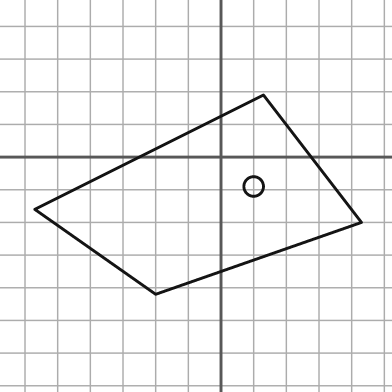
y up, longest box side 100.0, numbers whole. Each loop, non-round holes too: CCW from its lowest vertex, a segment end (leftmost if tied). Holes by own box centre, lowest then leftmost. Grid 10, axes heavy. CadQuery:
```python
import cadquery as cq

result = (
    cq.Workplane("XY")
    .moveTo(-20.0, -42.0)
    .lineTo(43.0, -20.0)
    .lineTo(13.0, 19.0)
    .lineTo(-57.0, -16.0)
    .close()
    .moveTo(10.0, -9.0)
    .circle(3.0)
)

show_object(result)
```